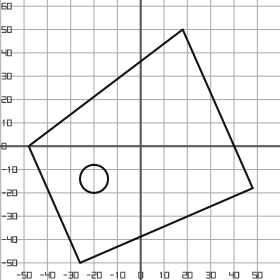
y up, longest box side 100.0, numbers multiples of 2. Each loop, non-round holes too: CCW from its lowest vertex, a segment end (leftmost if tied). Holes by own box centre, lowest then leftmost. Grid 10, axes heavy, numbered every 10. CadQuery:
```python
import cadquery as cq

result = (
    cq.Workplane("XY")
    .moveTo(-26.0, -50.0)
    .lineTo(48.0, -18.0)
    .lineTo(18.0, 50.0)
    .lineTo(-48.0, 0.0)
    .close()
    .moveTo(-20.0, -14.0)
    .circle(6.0)
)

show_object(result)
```